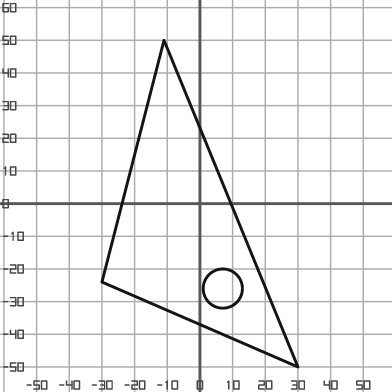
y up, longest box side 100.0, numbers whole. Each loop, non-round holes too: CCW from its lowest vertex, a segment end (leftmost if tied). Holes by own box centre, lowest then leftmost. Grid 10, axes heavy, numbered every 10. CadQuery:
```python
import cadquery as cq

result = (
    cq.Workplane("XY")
    .moveTo(30.0, -50.0)
    .lineTo(-11.0, 50.0)
    .lineTo(-30.0, -24.0)
    .close()
    .moveTo(7.0, -26.0)
    .circle(6.0)
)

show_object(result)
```